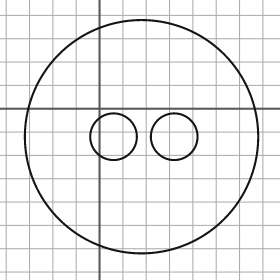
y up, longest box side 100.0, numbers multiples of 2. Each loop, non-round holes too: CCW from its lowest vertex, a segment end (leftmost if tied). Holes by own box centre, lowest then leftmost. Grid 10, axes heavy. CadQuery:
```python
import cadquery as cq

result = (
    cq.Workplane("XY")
    .moveTo(18.0, -12.0)
    .circle(50.0)
    .moveTo(6.0, -12.0)
    .circle(10.0)
    .moveTo(32.0, -12.0)
    .circle(10.0)
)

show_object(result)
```